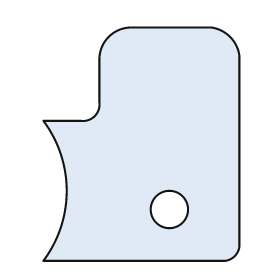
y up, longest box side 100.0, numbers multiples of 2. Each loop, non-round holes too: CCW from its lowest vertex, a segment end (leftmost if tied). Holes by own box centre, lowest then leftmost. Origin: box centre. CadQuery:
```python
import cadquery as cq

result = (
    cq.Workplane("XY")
    .moveTo(-42.0, -50.0)
    .lineTo(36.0, -50.0)
    .threePointArc((40.0, -48.0), (42.0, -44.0))
    .lineTo(42.0, 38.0)
    .threePointArc((38.0, 46.0), (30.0, 50.0))
    .lineTo(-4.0, 50.0)
    .threePointArc((-14.0, 46.0), (-18.0, 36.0))
    .lineTo(-18.0, 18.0)
    .threePointArc((-20.0, 12.0), (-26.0, 10.0))
    .lineTo(-42.0, 10.0)
    .threePointArc((-32.0, -20.0), (-42.0, -50.0))
    .close()
    .moveTo(12.0, -28.0)
    .circle(8.0)
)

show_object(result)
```